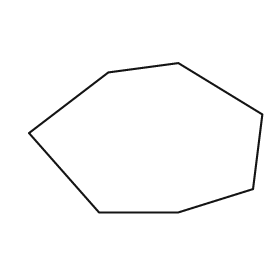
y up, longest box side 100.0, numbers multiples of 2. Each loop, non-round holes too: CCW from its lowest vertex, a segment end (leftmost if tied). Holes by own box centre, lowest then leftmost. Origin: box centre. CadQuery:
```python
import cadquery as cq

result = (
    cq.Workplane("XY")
    .moveTo(-20.0, -32.0)
    .lineTo(14.0, -32.0)
    .lineTo(46.0, -22.0)
    .lineTo(50.0, 10.0)
    .lineTo(14.0, 32.0)
    .lineTo(-16.0, 28.0)
    .lineTo(-50.0, 2.0)
    .close()
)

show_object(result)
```